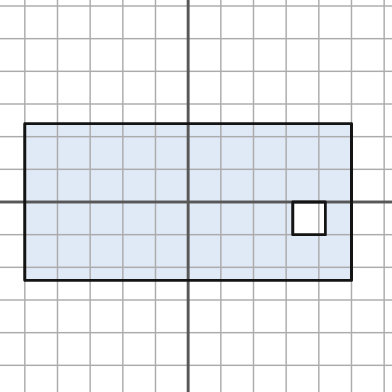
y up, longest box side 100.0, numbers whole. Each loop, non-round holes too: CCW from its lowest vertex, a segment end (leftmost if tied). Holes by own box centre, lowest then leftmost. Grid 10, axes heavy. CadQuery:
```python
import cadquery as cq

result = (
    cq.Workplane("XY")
    .moveTo(-50.0, -24.0)
    .lineTo(50.0, -24.0)
    .lineTo(50.0, 24.0)
    .lineTo(-50.0, 24.0)
    .close()
    .moveTo(32.0, -10.0)
    .lineTo(42.0, -10.0)
    .lineTo(42.0, 0.0)
    .lineTo(32.0, 0.0)
    .close()
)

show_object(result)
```